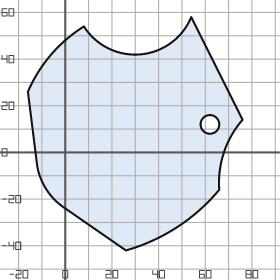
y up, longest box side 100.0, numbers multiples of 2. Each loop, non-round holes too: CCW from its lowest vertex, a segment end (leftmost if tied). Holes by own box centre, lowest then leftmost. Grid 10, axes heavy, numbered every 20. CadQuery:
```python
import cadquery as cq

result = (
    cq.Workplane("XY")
    .moveTo(26.0, -42.0)
    .threePointArc((48.0, -32.0), (66.0, -16.0))
    .threePointArc((68.0, 0.0), (76.0, 14.0))
    .lineTo(54.0, 58.0)
    .threePointArc((32.0, 42.0), (8.0, 54.0))
    .threePointArc((-6.0, 42.0), (-16.0, 26.0))
    .lineTo(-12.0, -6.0)
    .threePointArc((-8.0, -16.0), (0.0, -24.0))
    .close()
    .moveTo(62.0, 12.0)
    .circle(4.0)
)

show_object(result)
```